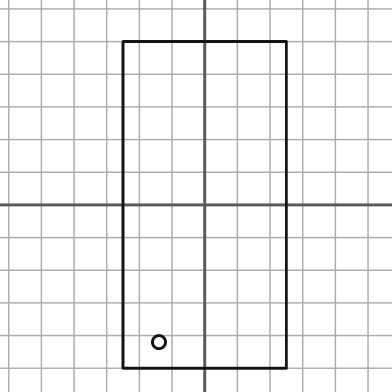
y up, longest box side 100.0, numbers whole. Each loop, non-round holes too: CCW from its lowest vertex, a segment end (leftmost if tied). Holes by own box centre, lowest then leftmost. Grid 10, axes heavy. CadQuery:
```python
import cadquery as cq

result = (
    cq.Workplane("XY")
    .moveTo(-25.0, -50.0)
    .lineTo(25.0, -50.0)
    .lineTo(25.0, 50.0)
    .lineTo(-25.0, 50.0)
    .close()
    .moveTo(-14.0, -42.0)
    .circle(2.0)
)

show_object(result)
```